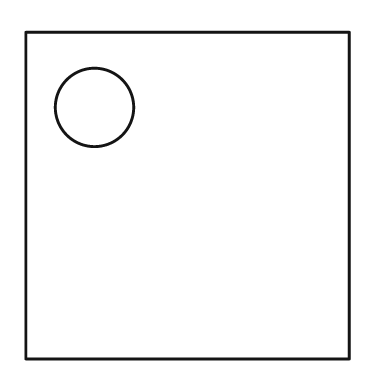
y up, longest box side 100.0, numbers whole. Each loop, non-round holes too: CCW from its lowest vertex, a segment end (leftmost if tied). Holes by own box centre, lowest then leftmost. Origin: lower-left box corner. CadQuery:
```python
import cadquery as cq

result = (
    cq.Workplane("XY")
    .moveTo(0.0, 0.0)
    .lineTo(99.0, 0.0)
    .lineTo(99.0, 100.0)
    .lineTo(0.0, 100.0)
    .close()
    .moveTo(21.0, 77.0)
    .circle(12.0)
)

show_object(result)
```